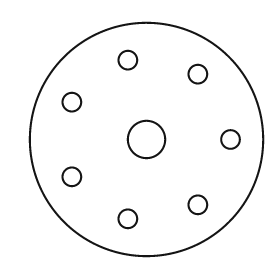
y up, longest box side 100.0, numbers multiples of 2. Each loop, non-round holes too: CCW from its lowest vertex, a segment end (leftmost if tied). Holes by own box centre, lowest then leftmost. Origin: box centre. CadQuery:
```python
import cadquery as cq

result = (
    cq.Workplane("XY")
    .moveTo(0.0, 0.0)
    .circle(50.0)
    .moveTo(-8.0, -34.0)
    .circle(4.0)
    .moveTo(22.0, -28.0)
    .circle(4.0)
    .moveTo(-32.0, -16.0)
    .circle(4.0)
    .moveTo(0.0, 0.0)
    .circle(8.0)
    .moveTo(36.0, 0.0)
    .circle(4.0)
    .moveTo(-32.0, 16.0)
    .circle(4.0)
    .moveTo(22.0, 28.0)
    .circle(4.0)
    .moveTo(-8.0, 34.0)
    .circle(4.0)
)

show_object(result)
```